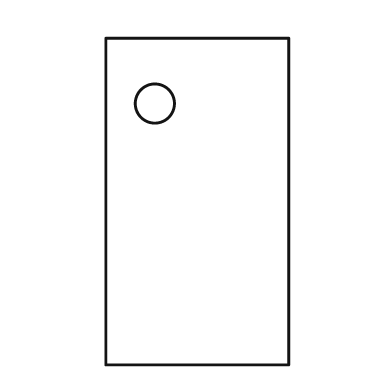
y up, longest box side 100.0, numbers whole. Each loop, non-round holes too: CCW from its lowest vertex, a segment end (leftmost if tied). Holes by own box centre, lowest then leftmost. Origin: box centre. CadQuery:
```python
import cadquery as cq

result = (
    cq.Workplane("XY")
    .moveTo(-28.0, -50.0)
    .lineTo(28.0, -50.0)
    .lineTo(28.0, 50.0)
    .lineTo(-28.0, 50.0)
    .close()
    .moveTo(-13.0, 30.0)
    .circle(6.0)
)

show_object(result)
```